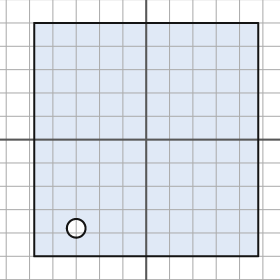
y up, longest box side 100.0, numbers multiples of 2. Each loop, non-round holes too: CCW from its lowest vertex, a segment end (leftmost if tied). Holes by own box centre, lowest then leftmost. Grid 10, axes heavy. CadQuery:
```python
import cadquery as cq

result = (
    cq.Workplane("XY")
    .moveTo(-48.0, -50.0)
    .lineTo(48.0, -50.0)
    .lineTo(48.0, 50.0)
    .lineTo(-48.0, 50.0)
    .close()
    .moveTo(-30.0, -38.0)
    .circle(4.0)
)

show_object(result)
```